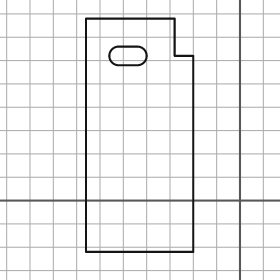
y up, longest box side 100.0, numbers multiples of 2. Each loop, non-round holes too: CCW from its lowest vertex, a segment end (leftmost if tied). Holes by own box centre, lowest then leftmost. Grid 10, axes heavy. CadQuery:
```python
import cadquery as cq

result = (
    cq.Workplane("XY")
    .moveTo(-66.0, -22.0)
    .lineTo(-20.0, -22.0)
    .lineTo(-20.0, 62.0)
    .lineTo(-28.0, 62.0)
    .lineTo(-28.0, 78.0)
    .lineTo(-66.0, 78.0)
    .close()
    .moveTo(-52.0, 58.0)
    .lineTo(-44.0, 58.0)
    .threePointArc((-40.0, 62.0), (-44.0, 66.0))
    .lineTo(-52.0, 66.0)
    .threePointArc((-56.0, 62.0), (-52.0, 58.0))
    .close()
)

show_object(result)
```